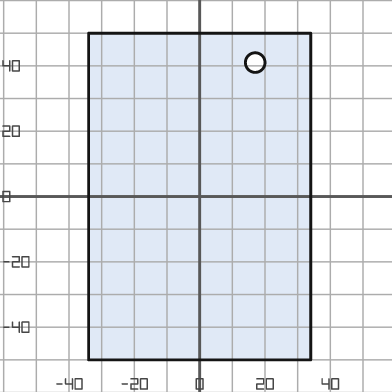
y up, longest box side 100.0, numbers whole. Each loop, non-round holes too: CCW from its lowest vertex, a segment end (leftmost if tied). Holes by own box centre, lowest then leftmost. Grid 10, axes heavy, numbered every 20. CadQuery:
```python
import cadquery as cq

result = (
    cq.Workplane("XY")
    .moveTo(-34.0, -50.0)
    .lineTo(34.0, -50.0)
    .lineTo(34.0, 50.0)
    .lineTo(-34.0, 50.0)
    .close()
    .moveTo(17.0, 41.0)
    .circle(3.0)
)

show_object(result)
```